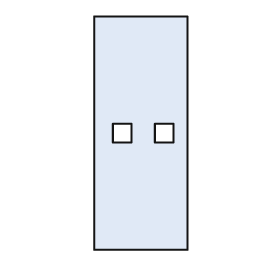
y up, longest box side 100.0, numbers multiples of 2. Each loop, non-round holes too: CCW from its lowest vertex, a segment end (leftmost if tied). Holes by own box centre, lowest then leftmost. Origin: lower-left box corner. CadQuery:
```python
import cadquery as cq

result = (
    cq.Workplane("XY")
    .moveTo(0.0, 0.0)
    .lineTo(40.0, 0.0)
    .lineTo(40.0, 100.0)
    .lineTo(0.0, 100.0)
    .close()
    .moveTo(8.0, 46.0)
    .lineTo(16.0, 46.0)
    .lineTo(16.0, 54.0)
    .lineTo(8.0, 54.0)
    .close()
    .moveTo(26.0, 46.0)
    .lineTo(34.0, 46.0)
    .lineTo(34.0, 54.0)
    .lineTo(26.0, 54.0)
    .close()
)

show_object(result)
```